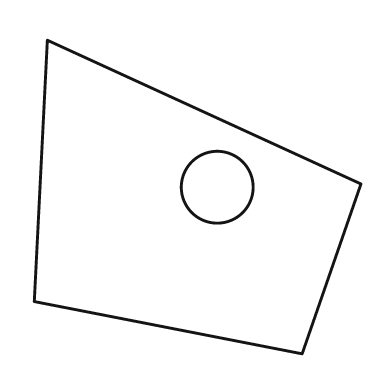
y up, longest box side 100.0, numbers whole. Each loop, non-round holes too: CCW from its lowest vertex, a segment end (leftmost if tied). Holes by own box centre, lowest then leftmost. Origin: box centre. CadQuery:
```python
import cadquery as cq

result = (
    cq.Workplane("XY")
    .moveTo(32.0, -48.0)
    .lineTo(50.0, 4.0)
    .lineTo(-46.0, 48.0)
    .lineTo(-50.0, -32.0)
    .close()
    .moveTo(6.0, 3.0)
    .circle(11.0)
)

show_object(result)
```